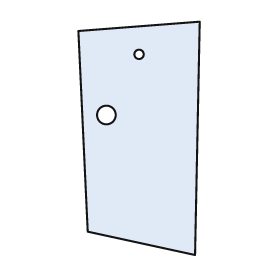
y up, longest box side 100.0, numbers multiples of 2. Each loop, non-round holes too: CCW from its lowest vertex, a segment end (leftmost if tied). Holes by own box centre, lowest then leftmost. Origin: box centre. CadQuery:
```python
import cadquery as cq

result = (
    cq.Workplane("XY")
    .moveTo(24.0, -50.0)
    .lineTo(26.0, 50.0)
    .lineTo(-26.0, 46.0)
    .lineTo(-22.0, -40.0)
    .close()
    .moveTo(-14.0, 10.0)
    .circle(4.0)
    .moveTo(0.0, 36.0)
    .circle(2.0)
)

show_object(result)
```